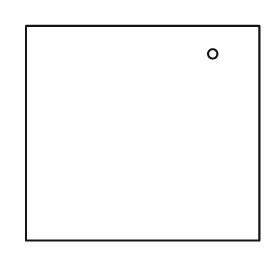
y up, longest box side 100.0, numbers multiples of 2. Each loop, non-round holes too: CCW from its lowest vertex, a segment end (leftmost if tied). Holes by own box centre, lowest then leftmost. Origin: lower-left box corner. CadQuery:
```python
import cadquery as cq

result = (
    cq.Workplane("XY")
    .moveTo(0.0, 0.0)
    .lineTo(100.0, 0.0)
    .lineTo(100.0, 92.0)
    .lineTo(0.0, 92.0)
    .close()
    .moveTo(80.0, 80.0)
    .circle(2.0)
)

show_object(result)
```